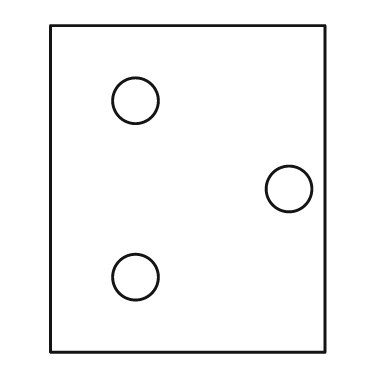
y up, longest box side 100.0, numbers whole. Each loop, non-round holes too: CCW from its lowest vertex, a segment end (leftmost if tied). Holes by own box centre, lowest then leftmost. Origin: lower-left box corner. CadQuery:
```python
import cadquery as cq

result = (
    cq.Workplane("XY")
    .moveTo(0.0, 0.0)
    .lineTo(84.0, 0.0)
    .lineTo(84.0, 100.0)
    .lineTo(0.0, 100.0)
    .close()
    .moveTo(26.0, 23.0)
    .circle(7.0)
    .moveTo(73.0, 50.0)
    .circle(7.0)
    .moveTo(26.0, 77.0)
    .circle(7.0)
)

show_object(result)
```